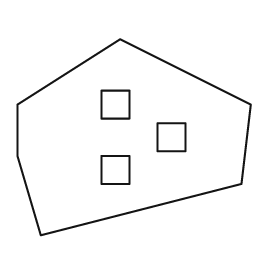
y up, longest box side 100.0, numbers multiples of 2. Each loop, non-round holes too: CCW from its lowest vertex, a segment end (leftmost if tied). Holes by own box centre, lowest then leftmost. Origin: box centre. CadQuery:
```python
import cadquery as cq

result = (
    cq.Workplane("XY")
    .moveTo(-40.0, -42.0)
    .lineTo(46.0, -20.0)
    .lineTo(50.0, 14.0)
    .lineTo(-6.0, 42.0)
    .lineTo(-50.0, 14.0)
    .lineTo(-50.0, -8.0)
    .close()
    .moveTo(-14.0, -20.0)
    .lineTo(-2.0, -20.0)
    .lineTo(-2.0, -8.0)
    .lineTo(-14.0, -8.0)
    .close()
    .moveTo(10.0, -6.0)
    .lineTo(22.0, -6.0)
    .lineTo(22.0, 6.0)
    .lineTo(10.0, 6.0)
    .close()
    .moveTo(-14.0, 8.0)
    .lineTo(-2.0, 8.0)
    .lineTo(-2.0, 20.0)
    .lineTo(-14.0, 20.0)
    .close()
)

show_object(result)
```